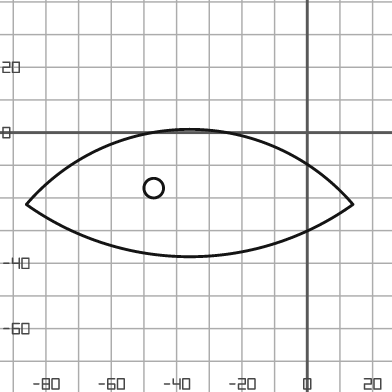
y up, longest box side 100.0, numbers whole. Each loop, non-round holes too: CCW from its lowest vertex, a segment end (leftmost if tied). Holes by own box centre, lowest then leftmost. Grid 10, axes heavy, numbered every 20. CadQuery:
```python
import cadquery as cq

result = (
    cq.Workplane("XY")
    .moveTo(-86.0, -22.0)
    .threePointArc((-36.0, -38.0), (14.0, -22.0))
    .threePointArc((-36.0, 1.0), (-86.0, -22.0))
    .close()
    .moveTo(-47.0, -17.0)
    .circle(3.0)
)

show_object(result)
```